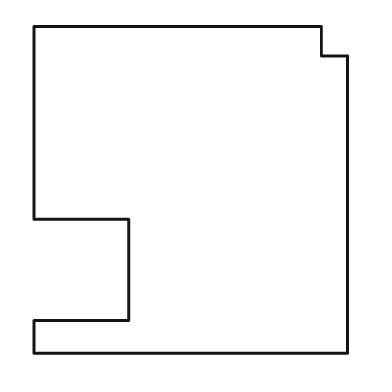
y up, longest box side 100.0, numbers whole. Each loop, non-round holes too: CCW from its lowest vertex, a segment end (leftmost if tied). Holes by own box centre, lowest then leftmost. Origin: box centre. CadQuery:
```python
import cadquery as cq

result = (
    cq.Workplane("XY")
    .moveTo(-48.0, -50.0)
    .lineTo(48.0, -50.0)
    .lineTo(48.0, 41.0)
    .lineTo(40.0, 41.0)
    .lineTo(40.0, 50.0)
    .lineTo(-48.0, 50.0)
    .lineTo(-48.0, -9.0)
    .lineTo(-19.0, -9.0)
    .lineTo(-19.0, -40.0)
    .lineTo(-48.0, -40.0)
    .close()
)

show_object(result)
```